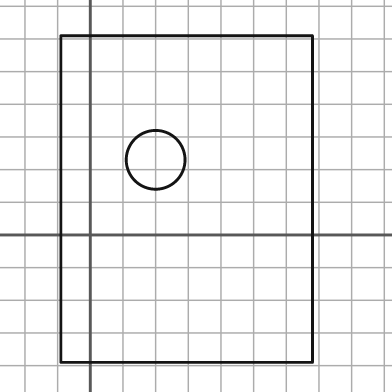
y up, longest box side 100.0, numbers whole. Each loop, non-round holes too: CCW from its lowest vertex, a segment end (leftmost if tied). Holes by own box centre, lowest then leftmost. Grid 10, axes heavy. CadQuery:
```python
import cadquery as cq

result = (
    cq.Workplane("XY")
    .moveTo(-9.0, -39.0)
    .lineTo(68.0, -39.0)
    .lineTo(68.0, 61.0)
    .lineTo(-9.0, 61.0)
    .close()
    .moveTo(20.0, 23.0)
    .circle(9.0)
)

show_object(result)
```